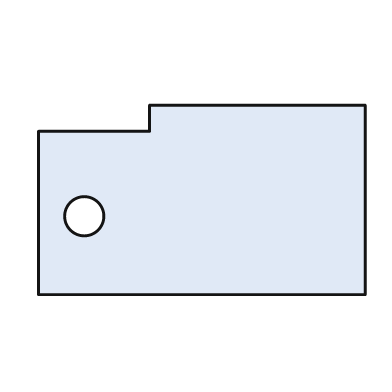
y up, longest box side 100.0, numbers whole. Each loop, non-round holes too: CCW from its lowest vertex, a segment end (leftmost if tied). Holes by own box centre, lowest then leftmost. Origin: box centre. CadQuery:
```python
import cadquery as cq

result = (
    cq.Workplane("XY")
    .moveTo(-50.0, -29.0)
    .lineTo(50.0, -29.0)
    .lineTo(50.0, 29.0)
    .lineTo(-16.0, 29.0)
    .lineTo(-16.0, 21.0)
    .lineTo(-50.0, 21.0)
    .close()
    .moveTo(-36.0, -5.0)
    .circle(6.0)
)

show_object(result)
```